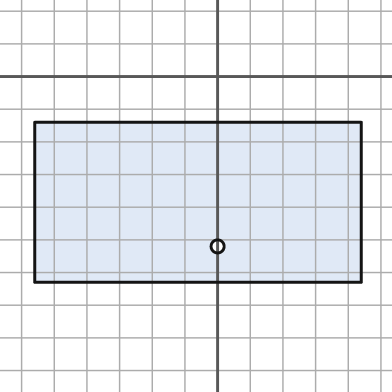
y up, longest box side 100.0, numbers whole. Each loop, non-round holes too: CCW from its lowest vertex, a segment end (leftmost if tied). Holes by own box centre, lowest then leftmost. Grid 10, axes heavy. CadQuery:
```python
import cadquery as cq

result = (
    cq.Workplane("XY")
    .moveTo(-56.0, -63.0)
    .lineTo(44.0, -63.0)
    .lineTo(44.0, -14.0)
    .lineTo(-56.0, -14.0)
    .close()
    .moveTo(0.0, -52.0)
    .circle(2.0)
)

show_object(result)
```